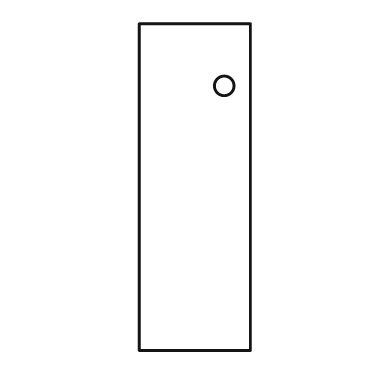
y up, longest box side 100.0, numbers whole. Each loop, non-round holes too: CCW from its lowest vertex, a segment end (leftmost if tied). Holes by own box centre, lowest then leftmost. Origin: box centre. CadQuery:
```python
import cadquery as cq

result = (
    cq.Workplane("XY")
    .moveTo(-17.0, -50.0)
    .lineTo(17.0, -50.0)
    .lineTo(17.0, 50.0)
    .lineTo(-17.0, 50.0)
    .close()
    .moveTo(9.0, 31.0)
    .circle(3.0)
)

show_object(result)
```